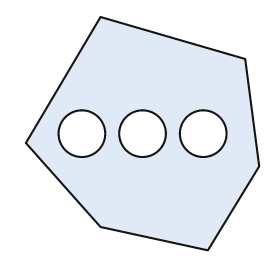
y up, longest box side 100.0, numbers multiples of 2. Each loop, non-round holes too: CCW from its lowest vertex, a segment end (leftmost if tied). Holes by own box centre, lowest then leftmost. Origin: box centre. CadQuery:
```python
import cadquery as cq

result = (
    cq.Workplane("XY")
    .moveTo(28.0, -50.0)
    .lineTo(50.0, -14.0)
    .lineTo(44.0, 32.0)
    .lineTo(-18.0, 50.0)
    .lineTo(-50.0, -4.0)
    .lineTo(-18.0, -40.0)
    .close()
    .moveTo(-26.0, 0.0)
    .circle(10.0)
    .moveTo(0.0, 0.0)
    .circle(10.0)
    .moveTo(26.0, 0.0)
    .circle(10.0)
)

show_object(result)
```